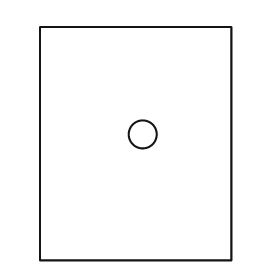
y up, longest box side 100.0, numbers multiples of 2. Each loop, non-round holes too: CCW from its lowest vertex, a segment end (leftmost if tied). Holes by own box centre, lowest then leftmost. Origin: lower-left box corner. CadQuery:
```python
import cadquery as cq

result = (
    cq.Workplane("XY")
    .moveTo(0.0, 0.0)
    .lineTo(82.0, 0.0)
    .lineTo(82.0, 100.0)
    .lineTo(0.0, 100.0)
    .close()
    .moveTo(44.0, 54.0)
    .circle(6.0)
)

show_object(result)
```